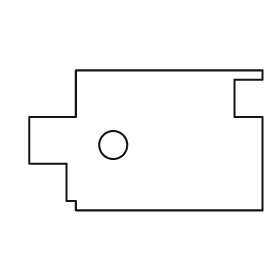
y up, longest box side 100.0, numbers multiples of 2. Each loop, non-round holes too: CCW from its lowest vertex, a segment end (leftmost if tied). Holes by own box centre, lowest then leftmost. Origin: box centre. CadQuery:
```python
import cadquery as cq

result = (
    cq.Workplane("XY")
    .moveTo(-30.0, -30.0)
    .lineTo(50.0, -30.0)
    .lineTo(50.0, 10.0)
    .lineTo(38.0, 10.0)
    .lineTo(38.0, 26.0)
    .lineTo(50.0, 26.0)
    .lineTo(50.0, 30.0)
    .lineTo(-30.0, 30.0)
    .lineTo(-30.0, 10.0)
    .lineTo(-50.0, 10.0)
    .lineTo(-50.0, -10.0)
    .lineTo(-34.0, -10.0)
    .lineTo(-34.0, -26.0)
    .lineTo(-30.0, -26.0)
    .close()
    .moveTo(-14.0, -2.0)
    .circle(6.0)
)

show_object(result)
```